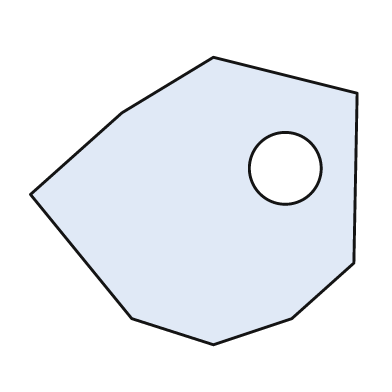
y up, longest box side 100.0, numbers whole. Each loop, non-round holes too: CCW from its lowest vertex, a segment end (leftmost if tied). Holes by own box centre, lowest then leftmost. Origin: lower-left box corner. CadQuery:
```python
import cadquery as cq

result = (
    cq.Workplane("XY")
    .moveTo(56.0, 0.0)
    .lineTo(80.0, 8.0)
    .lineTo(99.0, 25.0)
    .lineTo(100.0, 77.0)
    .lineTo(56.0, 88.0)
    .lineTo(28.0, 71.0)
    .lineTo(0.0, 46.0)
    .lineTo(31.0, 8.0)
    .close()
    .moveTo(78.0, 54.0)
    .circle(11.0)
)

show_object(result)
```